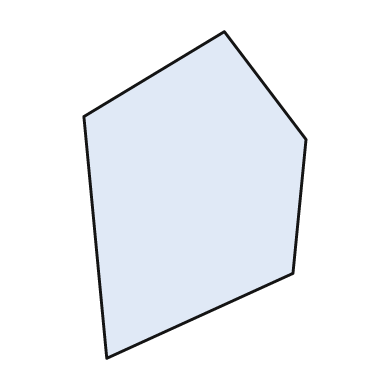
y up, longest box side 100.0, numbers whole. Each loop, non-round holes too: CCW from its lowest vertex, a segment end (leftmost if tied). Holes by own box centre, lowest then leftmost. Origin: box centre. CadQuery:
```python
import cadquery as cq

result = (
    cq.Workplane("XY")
    .moveTo(-27.0, -50.0)
    .lineTo(30.0, -24.0)
    .lineTo(34.0, 17.0)
    .lineTo(9.0, 50.0)
    .lineTo(-34.0, 24.0)
    .close()
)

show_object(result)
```